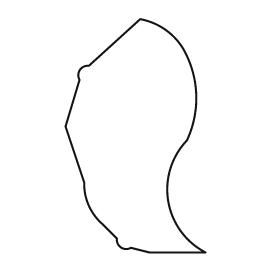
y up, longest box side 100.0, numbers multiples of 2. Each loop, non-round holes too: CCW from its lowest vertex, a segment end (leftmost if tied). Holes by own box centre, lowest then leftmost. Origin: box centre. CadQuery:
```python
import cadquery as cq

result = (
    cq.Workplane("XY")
    .moveTo(6.0, -50.0)
    .lineTo(30.0, -50.0)
    .threePointArc((14.0, -28.0), (22.0, -2.0))
    .threePointArc((26.0, 18.0), (20.0, 38.0))
    .threePointArc((12.0, 46.0), (2.0, 50.0))
    .lineTo(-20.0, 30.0)
    .threePointArc((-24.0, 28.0), (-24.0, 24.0))
    .lineTo(-30.0, 4.0)
    .lineTo(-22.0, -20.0)
    .threePointArc((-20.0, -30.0), (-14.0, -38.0))
    .lineTo(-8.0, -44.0)
    .threePointArc((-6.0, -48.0), (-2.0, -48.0))
    .close()
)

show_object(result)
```